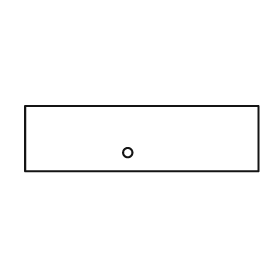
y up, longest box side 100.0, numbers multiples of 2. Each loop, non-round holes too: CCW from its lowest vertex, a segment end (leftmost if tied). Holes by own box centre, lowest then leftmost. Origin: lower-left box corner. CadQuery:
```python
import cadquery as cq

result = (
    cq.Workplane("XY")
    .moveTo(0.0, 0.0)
    .lineTo(100.0, 0.0)
    .lineTo(100.0, 28.0)
    .lineTo(0.0, 28.0)
    .close()
    .moveTo(44.0, 8.0)
    .circle(2.0)
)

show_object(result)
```